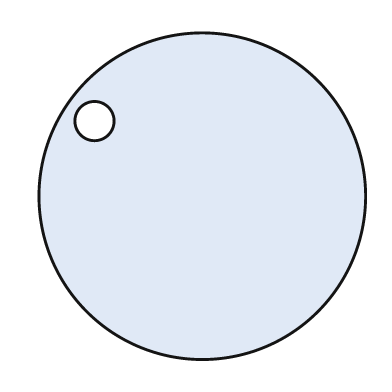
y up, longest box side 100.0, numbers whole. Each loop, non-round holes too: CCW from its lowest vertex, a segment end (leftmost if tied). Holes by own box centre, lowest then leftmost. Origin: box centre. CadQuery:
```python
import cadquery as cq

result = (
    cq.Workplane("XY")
    .moveTo(0.0, 0.0)
    .circle(50.0)
    .moveTo(-33.0, 23.0)
    .circle(6.0)
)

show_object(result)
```